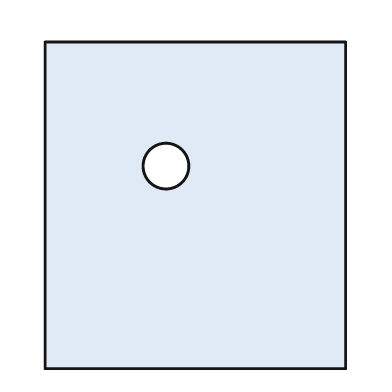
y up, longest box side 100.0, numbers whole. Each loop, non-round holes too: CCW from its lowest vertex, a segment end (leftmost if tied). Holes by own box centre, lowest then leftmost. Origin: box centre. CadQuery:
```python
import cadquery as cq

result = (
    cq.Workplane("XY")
    .moveTo(-46.0, -50.0)
    .lineTo(46.0, -50.0)
    .lineTo(46.0, 50.0)
    .lineTo(-46.0, 50.0)
    .close()
    .moveTo(-9.0, 12.0)
    .circle(7.0)
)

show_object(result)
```